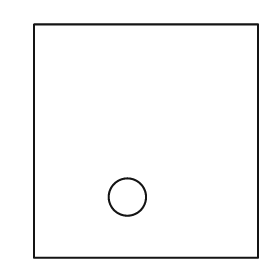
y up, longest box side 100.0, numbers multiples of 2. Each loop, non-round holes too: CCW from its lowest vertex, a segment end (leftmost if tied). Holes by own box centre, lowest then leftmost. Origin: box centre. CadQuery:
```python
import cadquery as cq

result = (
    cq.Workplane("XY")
    .moveTo(-48.0, -50.0)
    .lineTo(48.0, -50.0)
    .lineTo(48.0, 50.0)
    .lineTo(-48.0, 50.0)
    .close()
    .moveTo(-8.0, -24.0)
    .circle(8.0)
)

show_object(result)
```